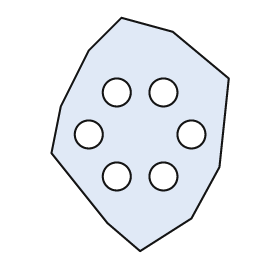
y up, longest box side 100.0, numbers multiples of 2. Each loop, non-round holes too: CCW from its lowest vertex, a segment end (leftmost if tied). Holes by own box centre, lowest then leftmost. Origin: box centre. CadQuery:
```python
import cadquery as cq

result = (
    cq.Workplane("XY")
    .moveTo(0.0, -50.0)
    .lineTo(22.0, -36.0)
    .lineTo(34.0, -14.0)
    .lineTo(38.0, 24.0)
    .lineTo(14.0, 44.0)
    .lineTo(-8.0, 50.0)
    .lineTo(-22.0, 36.0)
    .lineTo(-34.0, 12.0)
    .lineTo(-38.0, -8.0)
    .lineTo(-14.0, -38.0)
    .close()
    .moveTo(-10.0, -18.0)
    .circle(6.0)
    .moveTo(10.0, -18.0)
    .circle(6.0)
    .moveTo(-22.0, 0.0)
    .circle(6.0)
    .moveTo(22.0, 0.0)
    .circle(6.0)
    .moveTo(-10.0, 18.0)
    .circle(6.0)
    .moveTo(10.0, 18.0)
    .circle(6.0)
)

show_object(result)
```